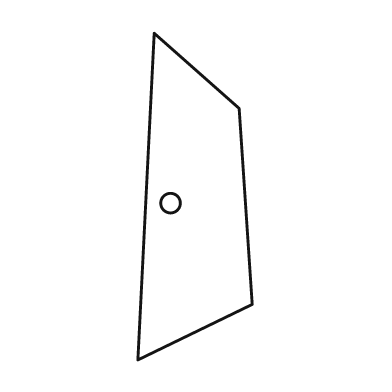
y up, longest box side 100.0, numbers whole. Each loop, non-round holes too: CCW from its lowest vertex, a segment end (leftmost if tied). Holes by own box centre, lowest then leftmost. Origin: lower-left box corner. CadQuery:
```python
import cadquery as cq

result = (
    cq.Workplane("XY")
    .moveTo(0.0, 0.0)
    .lineTo(35.0, 17.0)
    .lineTo(31.0, 77.0)
    .lineTo(5.0, 100.0)
    .close()
    .moveTo(10.0, 48.0)
    .circle(3.0)
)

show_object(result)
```